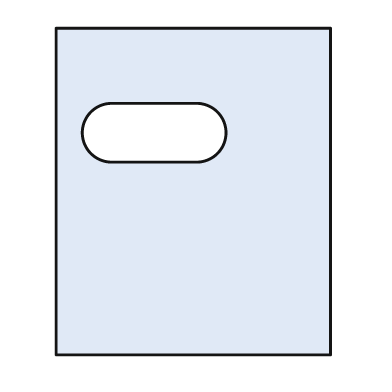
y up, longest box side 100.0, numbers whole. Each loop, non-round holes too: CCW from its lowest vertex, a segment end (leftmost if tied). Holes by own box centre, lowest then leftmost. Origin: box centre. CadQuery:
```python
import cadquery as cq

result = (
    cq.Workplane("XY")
    .moveTo(-42.0, -50.0)
    .lineTo(42.0, -50.0)
    .lineTo(42.0, 50.0)
    .lineTo(-42.0, 50.0)
    .close()
    .moveTo(-25.0, 9.0)
    .lineTo(1.0, 9.0)
    .threePointArc((10.0, 18.0), (1.0, 27.0))
    .lineTo(-25.0, 27.0)
    .threePointArc((-34.0, 18.0), (-25.0, 9.0))
    .close()
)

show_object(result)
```